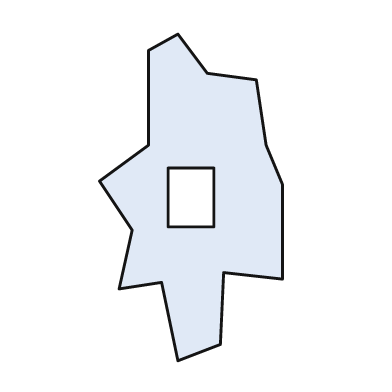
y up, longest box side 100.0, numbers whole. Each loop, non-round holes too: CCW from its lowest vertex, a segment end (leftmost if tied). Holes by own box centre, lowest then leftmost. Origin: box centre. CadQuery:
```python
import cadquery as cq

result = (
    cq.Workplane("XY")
    .moveTo(-4.0, -50.0)
    .lineTo(9.0, -45.0)
    .lineTo(10.0, -23.0)
    .lineTo(28.0, -25.0)
    .lineTo(28.0, 4.0)
    .lineTo(23.0, 16.0)
    .lineTo(20.0, 36.0)
    .lineTo(5.0, 38.0)
    .lineTo(-4.0, 50.0)
    .lineTo(-13.0, 45.0)
    .lineTo(-13.0, 16.0)
    .lineTo(-28.0, 5.0)
    .lineTo(-18.0, -10.0)
    .lineTo(-22.0, -28.0)
    .lineTo(-9.0, -26.0)
    .close()
    .moveTo(-7.0, -9.0)
    .lineTo(7.0, -9.0)
    .lineTo(7.0, 9.0)
    .lineTo(-7.0, 9.0)
    .close()
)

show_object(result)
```